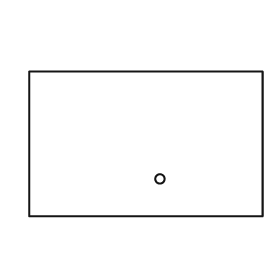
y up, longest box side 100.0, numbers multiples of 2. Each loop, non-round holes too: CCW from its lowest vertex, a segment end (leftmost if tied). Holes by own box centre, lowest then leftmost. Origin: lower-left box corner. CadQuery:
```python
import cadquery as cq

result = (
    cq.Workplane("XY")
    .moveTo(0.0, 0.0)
    .lineTo(100.0, 0.0)
    .lineTo(100.0, 62.0)
    .lineTo(0.0, 62.0)
    .close()
    .moveTo(56.0, 16.0)
    .circle(2.0)
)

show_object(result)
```